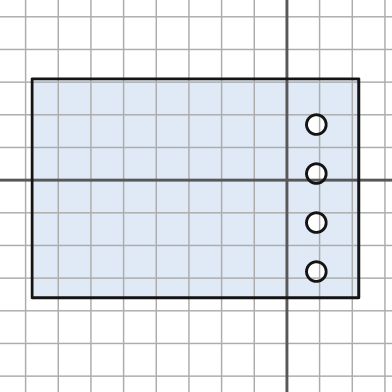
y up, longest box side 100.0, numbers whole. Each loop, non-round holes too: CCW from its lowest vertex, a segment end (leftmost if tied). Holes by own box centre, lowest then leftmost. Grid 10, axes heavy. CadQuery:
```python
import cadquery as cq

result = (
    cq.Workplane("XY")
    .moveTo(-78.0, -36.0)
    .lineTo(22.0, -36.0)
    .lineTo(22.0, 31.0)
    .lineTo(-78.0, 31.0)
    .close()
    .moveTo(9.0, -28.0)
    .circle(3.0)
    .moveTo(9.0, -13.0)
    .circle(3.0)
    .moveTo(9.0, 2.0)
    .circle(3.0)
    .moveTo(9.0, 17.0)
    .circle(3.0)
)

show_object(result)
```